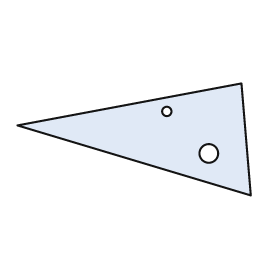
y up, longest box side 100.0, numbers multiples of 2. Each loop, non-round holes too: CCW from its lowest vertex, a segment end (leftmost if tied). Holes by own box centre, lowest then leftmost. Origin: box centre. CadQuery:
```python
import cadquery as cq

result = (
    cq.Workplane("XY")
    .moveTo(50.0, -24.0)
    .lineTo(46.0, 24.0)
    .lineTo(-50.0, 6.0)
    .close()
    .moveTo(32.0, -6.0)
    .circle(4.0)
    .moveTo(14.0, 12.0)
    .circle(2.0)
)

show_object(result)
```